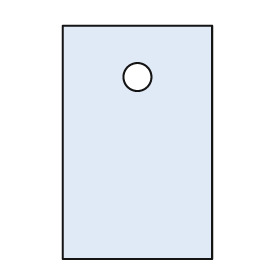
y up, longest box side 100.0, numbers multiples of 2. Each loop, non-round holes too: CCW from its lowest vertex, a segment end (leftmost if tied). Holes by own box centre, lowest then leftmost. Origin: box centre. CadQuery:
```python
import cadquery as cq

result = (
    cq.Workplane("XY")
    .moveTo(-32.0, -50.0)
    .lineTo(32.0, -50.0)
    .lineTo(32.0, 50.0)
    .lineTo(-32.0, 50.0)
    .close()
    .moveTo(0.0, 28.0)
    .circle(6.0)
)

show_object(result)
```